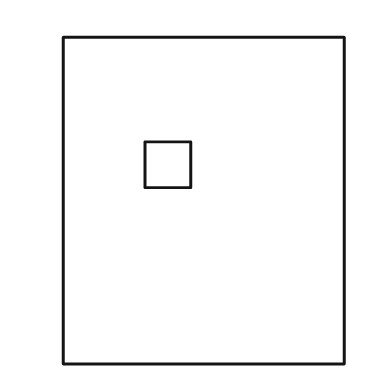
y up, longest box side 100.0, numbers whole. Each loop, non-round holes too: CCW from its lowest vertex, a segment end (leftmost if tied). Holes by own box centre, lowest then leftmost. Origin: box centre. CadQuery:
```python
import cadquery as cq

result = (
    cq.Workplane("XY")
    .moveTo(-43.0, -50.0)
    .lineTo(43.0, -50.0)
    .lineTo(43.0, 50.0)
    .lineTo(-43.0, 50.0)
    .close()
    .moveTo(-18.0, 4.0)
    .lineTo(-4.0, 4.0)
    .lineTo(-4.0, 18.0)
    .lineTo(-18.0, 18.0)
    .close()
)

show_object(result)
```